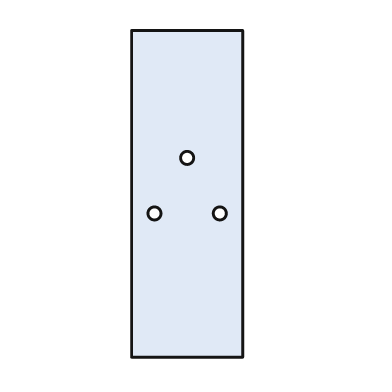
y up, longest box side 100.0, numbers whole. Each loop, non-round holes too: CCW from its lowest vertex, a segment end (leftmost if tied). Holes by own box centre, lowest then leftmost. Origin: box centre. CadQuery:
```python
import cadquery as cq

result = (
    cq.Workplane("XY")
    .moveTo(-17.0, -50.0)
    .lineTo(17.0, -50.0)
    .lineTo(17.0, 50.0)
    .lineTo(-17.0, 50.0)
    .close()
    .moveTo(-10.0, -6.0)
    .circle(2.0)
    .moveTo(10.0, -6.0)
    .circle(2.0)
    .moveTo(0.0, 11.0)
    .circle(2.0)
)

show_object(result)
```